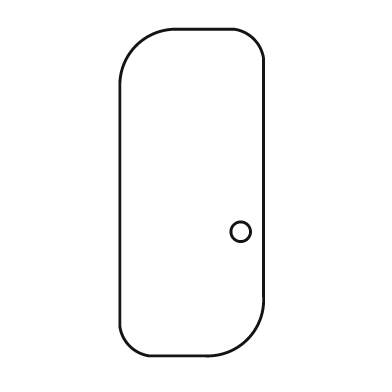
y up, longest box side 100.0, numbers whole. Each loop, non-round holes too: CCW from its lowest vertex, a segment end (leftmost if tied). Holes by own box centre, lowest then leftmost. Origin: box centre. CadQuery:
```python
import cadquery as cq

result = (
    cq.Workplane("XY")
    .moveTo(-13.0, -50.0)
    .lineTo(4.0, -50.0)
    .threePointArc((17.0, -45.0), (22.0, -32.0))
    .lineTo(22.0, 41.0)
    .threePointArc((19.0, 47.0), (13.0, 50.0))
    .lineTo(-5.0, 50.0)
    .threePointArc((-17.0, 45.0), (-22.0, 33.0))
    .lineTo(-22.0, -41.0)
    .threePointArc((-19.0, -47.0), (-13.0, -50.0))
    .close()
    .moveTo(15.0, -12.0)
    .circle(3.0)
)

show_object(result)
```